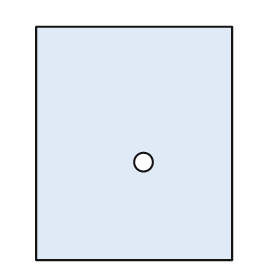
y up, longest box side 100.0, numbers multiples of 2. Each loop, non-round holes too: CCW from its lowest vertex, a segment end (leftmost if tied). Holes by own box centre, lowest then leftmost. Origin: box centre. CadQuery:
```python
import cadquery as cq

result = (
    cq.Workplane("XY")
    .moveTo(-42.0, -50.0)
    .lineTo(42.0, -50.0)
    .lineTo(42.0, 50.0)
    .lineTo(-42.0, 50.0)
    .close()
    .moveTo(4.0, -8.0)
    .circle(4.0)
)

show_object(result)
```